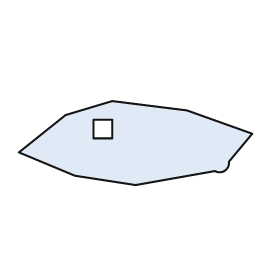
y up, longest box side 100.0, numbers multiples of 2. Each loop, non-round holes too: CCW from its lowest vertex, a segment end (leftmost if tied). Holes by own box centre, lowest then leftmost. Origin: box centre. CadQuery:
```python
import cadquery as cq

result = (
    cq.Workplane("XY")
    .moveTo(0.0, -18.0)
    .lineTo(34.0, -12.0)
    .threePointArc((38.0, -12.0), (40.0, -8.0))
    .lineTo(50.0, 4.0)
    .lineTo(22.0, 14.0)
    .lineTo(-10.0, 18.0)
    .lineTo(-30.0, 12.0)
    .lineTo(-50.0, -4.0)
    .lineTo(-26.0, -14.0)
    .close()
    .moveTo(-18.0, 2.0)
    .lineTo(-10.0, 2.0)
    .lineTo(-10.0, 10.0)
    .lineTo(-18.0, 10.0)
    .close()
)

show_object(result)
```